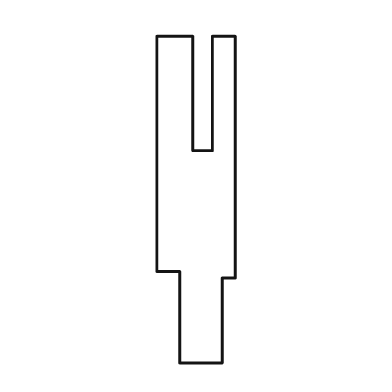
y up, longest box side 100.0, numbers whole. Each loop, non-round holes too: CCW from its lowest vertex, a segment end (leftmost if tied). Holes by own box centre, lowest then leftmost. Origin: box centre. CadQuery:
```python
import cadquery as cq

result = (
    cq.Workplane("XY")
    .moveTo(-5.0, -50.0)
    .lineTo(8.0, -50.0)
    .lineTo(8.0, -24.0)
    .lineTo(12.0, -24.0)
    .lineTo(12.0, 50.0)
    .lineTo(5.0, 50.0)
    .lineTo(5.0, 15.0)
    .lineTo(-1.0, 15.0)
    .lineTo(-1.0, 50.0)
    .lineTo(-12.0, 50.0)
    .lineTo(-12.0, -22.0)
    .lineTo(-5.0, -22.0)
    .close()
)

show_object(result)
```